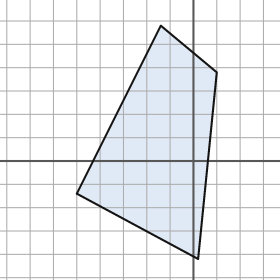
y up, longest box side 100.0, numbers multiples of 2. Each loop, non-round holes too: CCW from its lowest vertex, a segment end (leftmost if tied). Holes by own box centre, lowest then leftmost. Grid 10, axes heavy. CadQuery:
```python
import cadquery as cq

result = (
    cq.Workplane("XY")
    .moveTo(2.0, -42.0)
    .lineTo(10.0, 38.0)
    .lineTo(-14.0, 58.0)
    .lineTo(-50.0, -14.0)
    .close()
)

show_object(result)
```